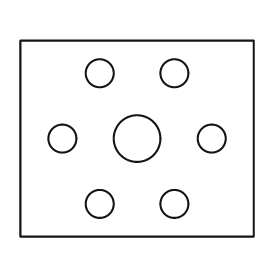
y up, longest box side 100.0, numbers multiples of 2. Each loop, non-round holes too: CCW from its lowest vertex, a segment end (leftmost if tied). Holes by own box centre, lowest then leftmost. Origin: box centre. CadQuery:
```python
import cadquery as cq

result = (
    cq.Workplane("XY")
    .moveTo(-50.0, -42.0)
    .lineTo(50.0, -42.0)
    .lineTo(50.0, 42.0)
    .lineTo(-50.0, 42.0)
    .close()
    .moveTo(-16.0, -28.0)
    .circle(6.0)
    .moveTo(16.0, -28.0)
    .circle(6.0)
    .moveTo(-32.0, 0.0)
    .circle(6.0)
    .moveTo(0.0, 0.0)
    .circle(10.0)
    .moveTo(32.0, 0.0)
    .circle(6.0)
    .moveTo(-16.0, 28.0)
    .circle(6.0)
    .moveTo(16.0, 28.0)
    .circle(6.0)
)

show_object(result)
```